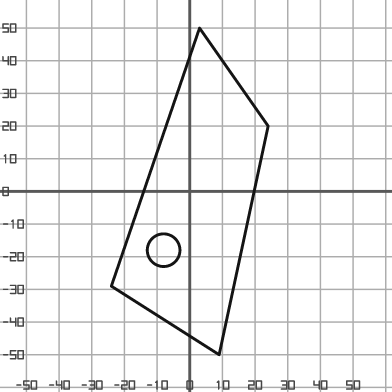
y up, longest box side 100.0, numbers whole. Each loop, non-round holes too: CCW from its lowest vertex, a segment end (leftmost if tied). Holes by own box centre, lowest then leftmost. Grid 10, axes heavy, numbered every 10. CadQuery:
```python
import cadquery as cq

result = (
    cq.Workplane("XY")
    .moveTo(9.0, -50.0)
    .lineTo(24.0, 20.0)
    .lineTo(3.0, 50.0)
    .lineTo(-24.0, -29.0)
    .close()
    .moveTo(-8.0, -18.0)
    .circle(5.0)
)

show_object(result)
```